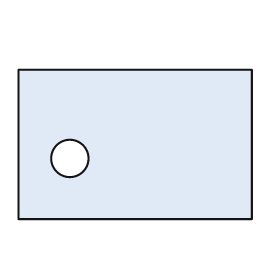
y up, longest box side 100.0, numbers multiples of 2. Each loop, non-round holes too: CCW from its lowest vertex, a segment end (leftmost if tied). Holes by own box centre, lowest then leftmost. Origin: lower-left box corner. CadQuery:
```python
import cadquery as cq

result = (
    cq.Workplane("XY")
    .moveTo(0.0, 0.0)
    .lineTo(100.0, 0.0)
    .lineTo(100.0, 64.0)
    .lineTo(0.0, 64.0)
    .close()
    .moveTo(22.0, 26.0)
    .circle(8.0)
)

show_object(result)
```